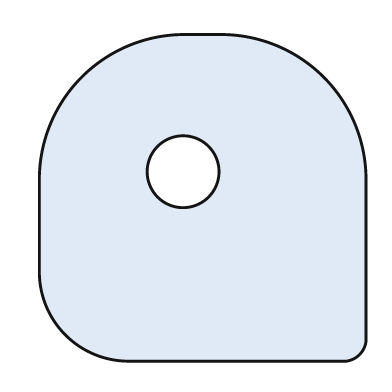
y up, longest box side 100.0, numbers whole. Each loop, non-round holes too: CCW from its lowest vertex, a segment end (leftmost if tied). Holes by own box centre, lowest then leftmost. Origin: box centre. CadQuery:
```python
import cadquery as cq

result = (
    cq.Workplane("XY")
    .moveTo(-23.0, -50.0)
    .lineTo(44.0, -50.0)
    .threePointArc((48.0, -48.0), (50.0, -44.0))
    .lineTo(50.0, 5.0)
    .threePointArc((37.0, 37.0), (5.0, 50.0))
    .lineTo(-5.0, 50.0)
    .threePointArc((-37.0, 37.0), (-50.0, 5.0))
    .lineTo(-50.0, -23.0)
    .threePointArc((-42.0, -42.0), (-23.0, -50.0))
    .close()
    .moveTo(-6.0, 8.0)
    .circle(11.0)
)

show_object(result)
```